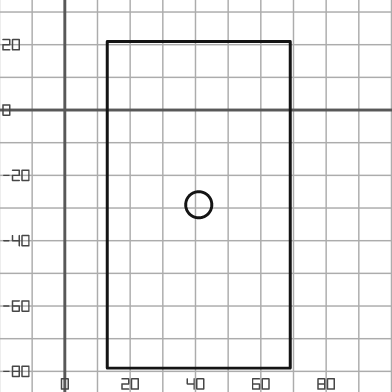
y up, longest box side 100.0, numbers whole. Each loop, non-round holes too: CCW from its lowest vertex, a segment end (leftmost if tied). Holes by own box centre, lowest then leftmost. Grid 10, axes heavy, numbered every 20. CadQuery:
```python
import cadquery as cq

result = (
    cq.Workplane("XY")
    .moveTo(13.0, -79.0)
    .lineTo(69.0, -79.0)
    .lineTo(69.0, 21.0)
    .lineTo(13.0, 21.0)
    .close()
    .moveTo(41.0, -29.0)
    .circle(4.0)
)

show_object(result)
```